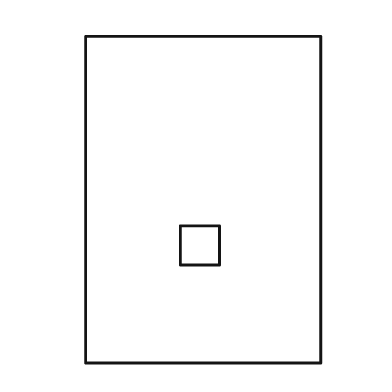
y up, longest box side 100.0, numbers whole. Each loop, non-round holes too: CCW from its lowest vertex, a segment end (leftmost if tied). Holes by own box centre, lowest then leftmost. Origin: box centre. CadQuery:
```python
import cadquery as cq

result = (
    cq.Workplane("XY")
    .moveTo(-36.0, -50.0)
    .lineTo(36.0, -50.0)
    .lineTo(36.0, 50.0)
    .lineTo(-36.0, 50.0)
    .close()
    .moveTo(-7.0, -20.0)
    .lineTo(5.0, -20.0)
    .lineTo(5.0, -8.0)
    .lineTo(-7.0, -8.0)
    .close()
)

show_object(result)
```